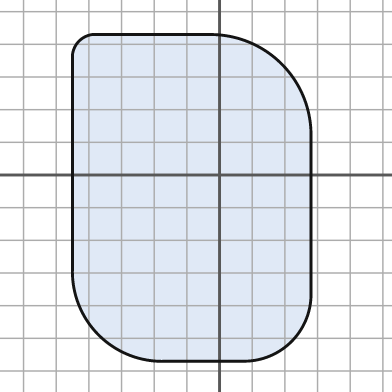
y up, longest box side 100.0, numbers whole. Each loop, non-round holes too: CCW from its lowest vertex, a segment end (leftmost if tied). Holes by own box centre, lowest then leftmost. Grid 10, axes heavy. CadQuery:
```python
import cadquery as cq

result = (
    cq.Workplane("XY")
    .moveTo(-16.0, -57.0)
    .lineTo(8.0, -57.0)
    .threePointArc((22.0, -51.0), (28.0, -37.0))
    .lineTo(28.0, 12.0)
    .threePointArc((19.0, 34.0), (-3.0, 43.0))
    .lineTo(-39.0, 43.0)
    .threePointArc((-43.0, 41.0), (-45.0, 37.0))
    .lineTo(-45.0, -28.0)
    .threePointArc((-37.0, -49.0), (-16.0, -57.0))
    .close()
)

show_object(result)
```